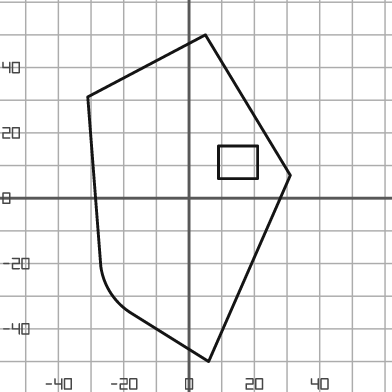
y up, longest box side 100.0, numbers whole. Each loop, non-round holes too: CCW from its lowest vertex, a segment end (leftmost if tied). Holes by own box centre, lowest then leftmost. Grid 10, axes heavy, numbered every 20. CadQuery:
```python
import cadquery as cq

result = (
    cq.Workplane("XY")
    .moveTo(6.0, -50.0)
    .lineTo(31.0, 7.0)
    .lineTo(5.0, 50.0)
    .lineTo(-31.0, 31.0)
    .lineTo(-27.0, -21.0)
    .threePointArc((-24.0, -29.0), (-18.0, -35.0))
    .close()
    .moveTo(9.0, 6.0)
    .lineTo(21.0, 6.0)
    .lineTo(21.0, 16.0)
    .lineTo(9.0, 16.0)
    .close()
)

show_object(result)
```